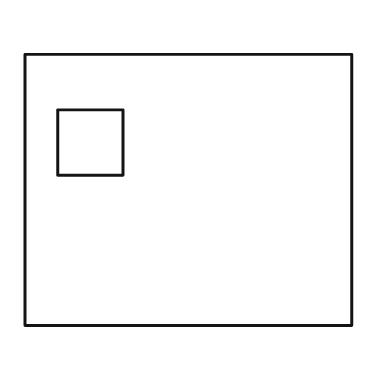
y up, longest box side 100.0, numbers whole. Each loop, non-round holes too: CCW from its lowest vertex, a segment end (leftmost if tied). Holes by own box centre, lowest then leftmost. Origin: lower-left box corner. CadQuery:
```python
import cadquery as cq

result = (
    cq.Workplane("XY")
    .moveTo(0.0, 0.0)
    .lineTo(100.0, 0.0)
    .lineTo(100.0, 83.0)
    .lineTo(0.0, 83.0)
    .close()
    .moveTo(10.0, 46.0)
    .lineTo(30.0, 46.0)
    .lineTo(30.0, 66.0)
    .lineTo(10.0, 66.0)
    .close()
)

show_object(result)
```